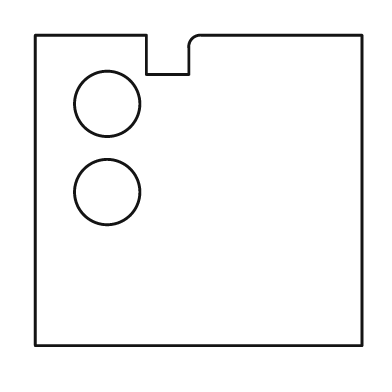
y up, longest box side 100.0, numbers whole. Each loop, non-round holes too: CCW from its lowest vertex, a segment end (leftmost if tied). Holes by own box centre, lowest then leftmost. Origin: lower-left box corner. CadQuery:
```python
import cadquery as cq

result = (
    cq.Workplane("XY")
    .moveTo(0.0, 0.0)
    .lineTo(100.0, 0.0)
    .lineTo(100.0, 95.0)
    .lineTo(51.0, 95.0)
    .threePointArc((48.0, 94.0), (47.0, 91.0))
    .lineTo(47.0, 83.0)
    .lineTo(34.0, 83.0)
    .lineTo(34.0, 95.0)
    .lineTo(0.0, 95.0)
    .close()
    .moveTo(22.0, 47.0)
    .circle(10.0)
    .moveTo(22.0, 74.0)
    .circle(10.0)
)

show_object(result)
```